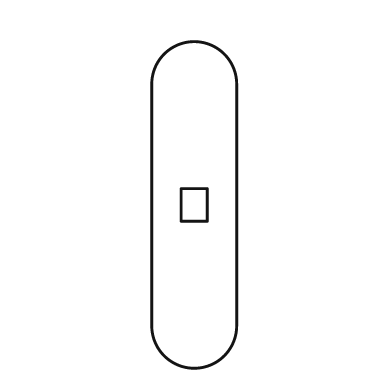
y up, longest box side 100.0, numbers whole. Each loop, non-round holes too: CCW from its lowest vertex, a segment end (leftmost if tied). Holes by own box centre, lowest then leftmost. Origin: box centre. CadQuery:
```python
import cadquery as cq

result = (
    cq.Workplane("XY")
    .moveTo(-13.0, -37.0)
    .threePointArc((0.0, -50.0), (13.0, -37.0))
    .lineTo(13.0, 37.0)
    .threePointArc((0.0, 50.0), (-13.0, 37.0))
    .close()
    .moveTo(-4.0, -5.0)
    .lineTo(4.0, -5.0)
    .lineTo(4.0, 5.0)
    .lineTo(-4.0, 5.0)
    .close()
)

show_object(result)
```